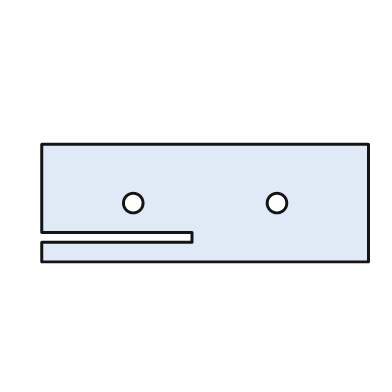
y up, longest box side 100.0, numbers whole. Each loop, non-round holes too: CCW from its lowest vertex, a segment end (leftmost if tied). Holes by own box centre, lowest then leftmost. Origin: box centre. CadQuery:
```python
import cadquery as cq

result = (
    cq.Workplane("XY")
    .moveTo(-50.0, -18.0)
    .lineTo(50.0, -18.0)
    .lineTo(50.0, 18.0)
    .lineTo(-50.0, 18.0)
    .lineTo(-50.0, -9.0)
    .lineTo(-4.0, -9.0)
    .lineTo(-4.0, -12.0)
    .lineTo(-50.0, -12.0)
    .close()
    .moveTo(-22.0, 0.0)
    .circle(3.0)
    .moveTo(22.0, 0.0)
    .circle(3.0)
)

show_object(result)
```